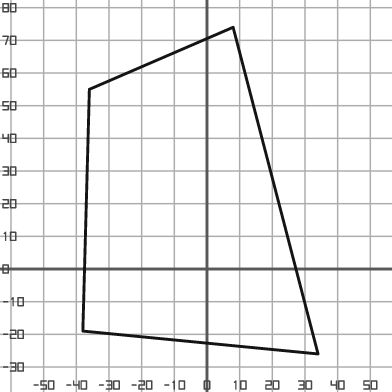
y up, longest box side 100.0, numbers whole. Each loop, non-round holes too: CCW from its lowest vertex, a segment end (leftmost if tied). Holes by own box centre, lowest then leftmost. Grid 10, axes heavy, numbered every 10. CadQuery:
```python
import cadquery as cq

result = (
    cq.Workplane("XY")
    .moveTo(34.0, -26.0)
    .lineTo(8.0, 74.0)
    .lineTo(-36.0, 55.0)
    .lineTo(-38.0, -19.0)
    .close()
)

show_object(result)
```